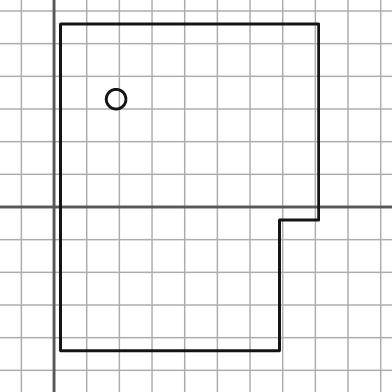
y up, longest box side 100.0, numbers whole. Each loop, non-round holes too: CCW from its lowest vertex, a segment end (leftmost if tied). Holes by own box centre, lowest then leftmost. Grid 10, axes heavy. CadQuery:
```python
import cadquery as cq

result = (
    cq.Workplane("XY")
    .moveTo(2.0, -44.0)
    .lineTo(69.0, -44.0)
    .lineTo(69.0, -4.0)
    .lineTo(81.0, -4.0)
    .lineTo(81.0, 56.0)
    .lineTo(2.0, 56.0)
    .close()
    .moveTo(19.0, 33.0)
    .circle(3.0)
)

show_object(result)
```